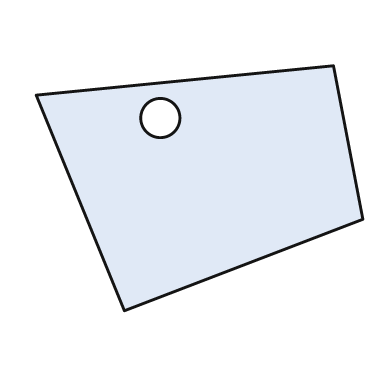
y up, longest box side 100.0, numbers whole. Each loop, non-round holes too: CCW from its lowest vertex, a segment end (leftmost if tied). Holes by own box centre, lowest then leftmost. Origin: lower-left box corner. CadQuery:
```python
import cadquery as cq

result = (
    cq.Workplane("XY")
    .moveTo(27.0, 0.0)
    .lineTo(100.0, 28.0)
    .lineTo(91.0, 75.0)
    .lineTo(0.0, 66.0)
    .close()
    .moveTo(38.0, 59.0)
    .circle(6.0)
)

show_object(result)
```